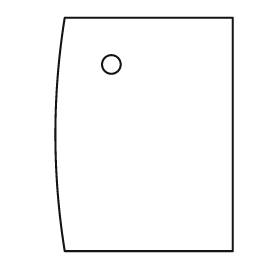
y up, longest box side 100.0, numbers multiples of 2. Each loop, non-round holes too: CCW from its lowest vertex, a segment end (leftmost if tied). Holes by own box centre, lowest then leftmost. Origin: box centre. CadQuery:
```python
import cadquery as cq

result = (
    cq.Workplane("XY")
    .moveTo(-34.0, -50.0)
    .lineTo(38.0, -50.0)
    .lineTo(38.0, 50.0)
    .lineTo(-34.0, 50.0)
    .threePointArc((-38.0, 0.0), (-34.0, -50.0))
    .close()
    .moveTo(-14.0, 30.0)
    .circle(4.0)
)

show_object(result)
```